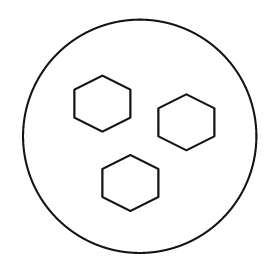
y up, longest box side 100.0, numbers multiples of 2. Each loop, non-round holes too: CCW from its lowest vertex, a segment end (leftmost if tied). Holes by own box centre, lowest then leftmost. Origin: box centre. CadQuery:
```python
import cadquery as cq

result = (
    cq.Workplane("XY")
    .moveTo(0.0, 0.0)
    .circle(50.0)
    .moveTo(-4.0, -32.0)
    .lineTo(8.0, -26.0)
    .lineTo(8.0, -14.0)
    .lineTo(-4.0, -8.0)
    .lineTo(-16.0, -14.0)
    .lineTo(-16.0, -26.0)
    .close()
    .moveTo(20.0, -6.0)
    .lineTo(32.0, 0.0)
    .lineTo(32.0, 12.0)
    .lineTo(20.0, 18.0)
    .lineTo(8.0, 12.0)
    .lineTo(8.0, 0.0)
    .close()
    .moveTo(-16.0, 2.0)
    .lineTo(-4.0, 8.0)
    .lineTo(-4.0, 20.0)
    .lineTo(-16.0, 26.0)
    .lineTo(-28.0, 20.0)
    .lineTo(-28.0, 8.0)
    .close()
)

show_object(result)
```